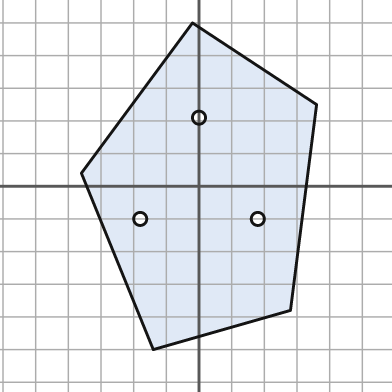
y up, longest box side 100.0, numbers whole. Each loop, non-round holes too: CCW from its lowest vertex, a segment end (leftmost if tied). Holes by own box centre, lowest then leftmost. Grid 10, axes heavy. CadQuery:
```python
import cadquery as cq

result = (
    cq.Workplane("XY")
    .moveTo(-14.0, -50.0)
    .lineTo(28.0, -38.0)
    .lineTo(36.0, 25.0)
    .lineTo(-2.0, 50.0)
    .lineTo(-36.0, 4.0)
    .close()
    .moveTo(-18.0, -10.0)
    .circle(2.0)
    .moveTo(18.0, -10.0)
    .circle(2.0)
    .moveTo(0.0, 21.0)
    .circle(2.0)
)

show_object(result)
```